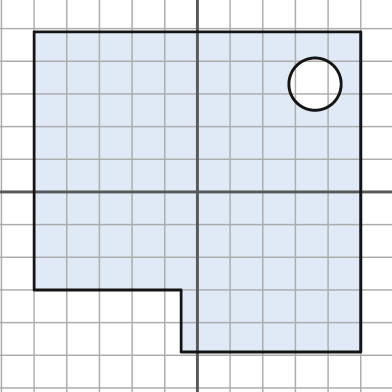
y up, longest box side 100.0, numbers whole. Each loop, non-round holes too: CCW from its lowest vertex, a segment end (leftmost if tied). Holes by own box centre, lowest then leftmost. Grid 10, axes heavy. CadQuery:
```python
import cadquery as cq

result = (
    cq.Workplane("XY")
    .moveTo(-5.0, -49.0)
    .lineTo(50.0, -49.0)
    .lineTo(50.0, 49.0)
    .lineTo(-50.0, 49.0)
    .lineTo(-50.0, -30.0)
    .lineTo(-5.0, -30.0)
    .close()
    .moveTo(36.0, 33.0)
    .circle(8.0)
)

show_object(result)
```